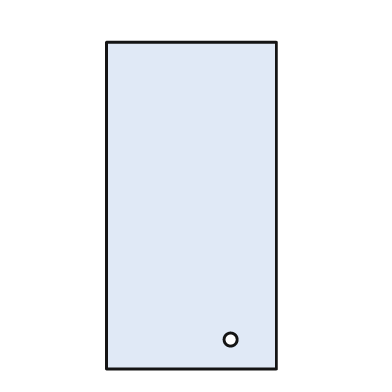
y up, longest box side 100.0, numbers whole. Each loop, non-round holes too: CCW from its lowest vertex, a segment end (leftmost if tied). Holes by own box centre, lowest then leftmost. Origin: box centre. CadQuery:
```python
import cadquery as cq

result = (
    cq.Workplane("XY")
    .moveTo(-26.0, -50.0)
    .lineTo(26.0, -50.0)
    .lineTo(26.0, 50.0)
    .lineTo(-26.0, 50.0)
    .close()
    .moveTo(12.0, -41.0)
    .circle(2.0)
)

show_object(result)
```